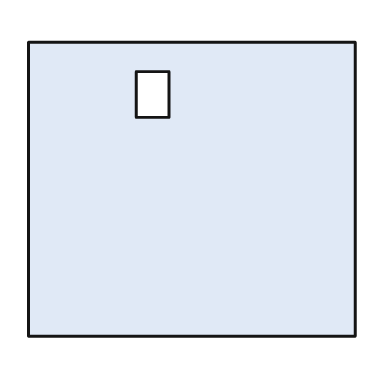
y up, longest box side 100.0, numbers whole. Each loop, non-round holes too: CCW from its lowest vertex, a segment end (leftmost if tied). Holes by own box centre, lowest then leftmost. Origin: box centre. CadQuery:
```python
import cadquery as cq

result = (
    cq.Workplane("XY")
    .moveTo(-50.0, -45.0)
    .lineTo(50.0, -45.0)
    .lineTo(50.0, 45.0)
    .lineTo(-50.0, 45.0)
    .close()
    .moveTo(-17.0, 22.0)
    .lineTo(-7.0, 22.0)
    .lineTo(-7.0, 36.0)
    .lineTo(-17.0, 36.0)
    .close()
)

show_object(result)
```